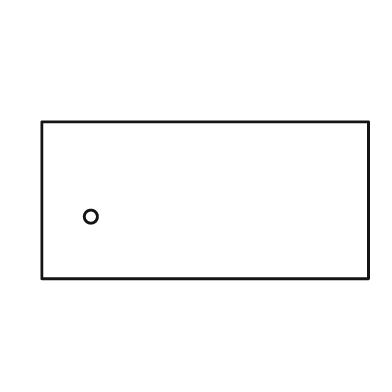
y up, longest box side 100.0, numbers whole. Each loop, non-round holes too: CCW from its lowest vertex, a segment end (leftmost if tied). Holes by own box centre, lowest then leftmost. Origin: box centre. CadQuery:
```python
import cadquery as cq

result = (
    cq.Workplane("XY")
    .moveTo(-50.0, -24.0)
    .lineTo(50.0, -24.0)
    .lineTo(50.0, 24.0)
    .lineTo(-50.0, 24.0)
    .close()
    .moveTo(-35.0, -5.0)
    .circle(2.0)
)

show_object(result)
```